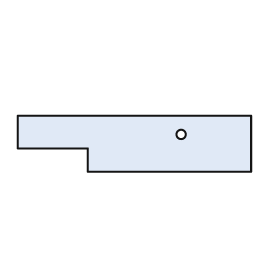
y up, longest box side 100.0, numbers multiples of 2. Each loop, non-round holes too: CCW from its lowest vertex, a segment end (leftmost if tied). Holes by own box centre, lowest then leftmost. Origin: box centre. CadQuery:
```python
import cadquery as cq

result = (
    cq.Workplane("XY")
    .moveTo(-20.0, -12.0)
    .lineTo(50.0, -12.0)
    .lineTo(50.0, 12.0)
    .lineTo(-50.0, 12.0)
    .lineTo(-50.0, -2.0)
    .lineTo(-20.0, -2.0)
    .close()
    .moveTo(20.0, 4.0)
    .circle(2.0)
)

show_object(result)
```